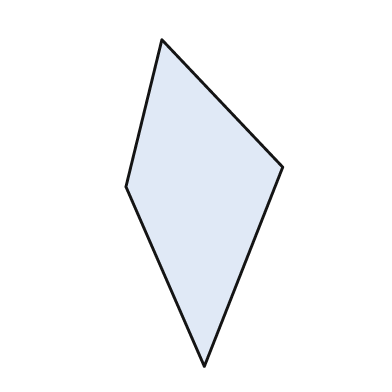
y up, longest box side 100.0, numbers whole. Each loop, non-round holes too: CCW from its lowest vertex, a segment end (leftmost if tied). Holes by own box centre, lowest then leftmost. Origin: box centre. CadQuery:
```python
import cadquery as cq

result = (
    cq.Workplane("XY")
    .moveTo(0.0, -50.0)
    .lineTo(24.0, 11.0)
    .lineTo(-13.0, 50.0)
    .lineTo(-24.0, 5.0)
    .close()
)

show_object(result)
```